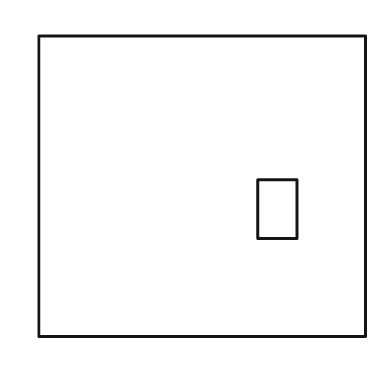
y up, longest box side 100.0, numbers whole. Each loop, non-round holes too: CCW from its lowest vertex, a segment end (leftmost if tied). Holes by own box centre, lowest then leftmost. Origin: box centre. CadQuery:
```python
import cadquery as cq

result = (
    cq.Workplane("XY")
    .moveTo(-50.0, -46.0)
    .lineTo(50.0, -46.0)
    .lineTo(50.0, 46.0)
    .lineTo(-50.0, 46.0)
    .close()
    .moveTo(17.0, -16.0)
    .lineTo(29.0, -16.0)
    .lineTo(29.0, 2.0)
    .lineTo(17.0, 2.0)
    .close()
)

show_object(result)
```